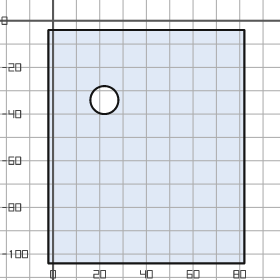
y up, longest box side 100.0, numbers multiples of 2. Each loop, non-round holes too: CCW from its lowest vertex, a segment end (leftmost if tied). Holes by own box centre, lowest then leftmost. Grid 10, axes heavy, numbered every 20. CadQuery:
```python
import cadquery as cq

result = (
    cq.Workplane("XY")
    .moveTo(-2.0, -104.0)
    .lineTo(82.0, -104.0)
    .lineTo(82.0, -4.0)
    .lineTo(-2.0, -4.0)
    .close()
    .moveTo(22.0, -34.0)
    .circle(6.0)
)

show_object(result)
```